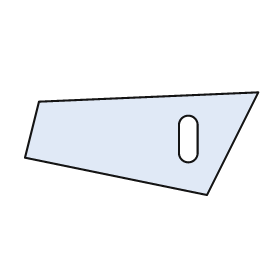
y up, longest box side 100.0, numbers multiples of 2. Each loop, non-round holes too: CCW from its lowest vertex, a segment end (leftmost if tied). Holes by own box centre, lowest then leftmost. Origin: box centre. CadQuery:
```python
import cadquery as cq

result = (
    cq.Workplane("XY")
    .moveTo(28.0, -22.0)
    .lineTo(50.0, 22.0)
    .lineTo(-44.0, 18.0)
    .lineTo(-50.0, -6.0)
    .close()
    .moveTo(16.0, -4.0)
    .threePointArc((20.0, -8.0), (24.0, -4.0))
    .lineTo(24.0, 8.0)
    .threePointArc((20.0, 12.0), (16.0, 8.0))
    .close()
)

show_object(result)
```